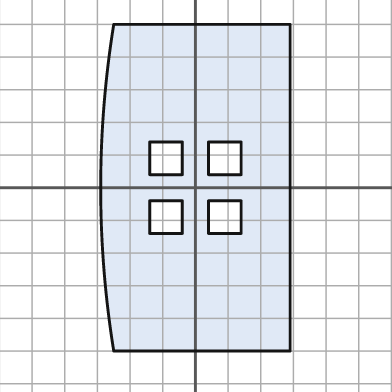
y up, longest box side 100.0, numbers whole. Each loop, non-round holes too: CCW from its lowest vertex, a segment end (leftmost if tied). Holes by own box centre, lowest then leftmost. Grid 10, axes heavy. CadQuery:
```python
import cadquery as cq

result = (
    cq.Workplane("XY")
    .moveTo(-25.0, -50.0)
    .lineTo(29.0, -50.0)
    .lineTo(29.0, 50.0)
    .lineTo(-25.0, 50.0)
    .threePointArc((-29.0, 0.0), (-25.0, -50.0))
    .close()
    .moveTo(-14.0, -14.0)
    .lineTo(-4.0, -14.0)
    .lineTo(-4.0, -4.0)
    .lineTo(-14.0, -4.0)
    .close()
    .moveTo(4.0, -14.0)
    .lineTo(14.0, -14.0)
    .lineTo(14.0, -4.0)
    .lineTo(4.0, -4.0)
    .close()
    .moveTo(-14.0, 4.0)
    .lineTo(-4.0, 4.0)
    .lineTo(-4.0, 14.0)
    .lineTo(-14.0, 14.0)
    .close()
    .moveTo(4.0, 4.0)
    .lineTo(14.0, 4.0)
    .lineTo(14.0, 14.0)
    .lineTo(4.0, 14.0)
    .close()
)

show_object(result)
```